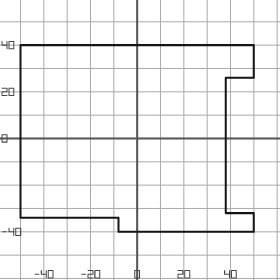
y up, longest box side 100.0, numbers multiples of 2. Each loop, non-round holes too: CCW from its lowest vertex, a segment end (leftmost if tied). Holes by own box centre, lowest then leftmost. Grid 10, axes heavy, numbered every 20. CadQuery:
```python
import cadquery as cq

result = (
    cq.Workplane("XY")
    .moveTo(-8.0, -40.0)
    .lineTo(50.0, -40.0)
    .lineTo(50.0, -32.0)
    .lineTo(38.0, -32.0)
    .lineTo(38.0, 26.0)
    .lineTo(50.0, 26.0)
    .lineTo(50.0, 40.0)
    .lineTo(-50.0, 40.0)
    .lineTo(-50.0, -34.0)
    .lineTo(-8.0, -34.0)
    .close()
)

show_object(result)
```